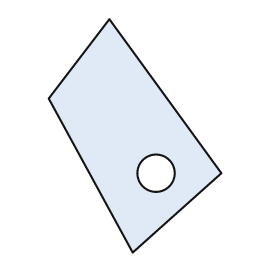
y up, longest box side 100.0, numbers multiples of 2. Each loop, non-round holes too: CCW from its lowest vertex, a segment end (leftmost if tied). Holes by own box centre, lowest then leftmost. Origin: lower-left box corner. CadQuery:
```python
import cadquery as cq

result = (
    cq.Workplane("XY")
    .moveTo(36.0, 0.0)
    .lineTo(74.0, 34.0)
    .lineTo(26.0, 100.0)
    .lineTo(0.0, 66.0)
    .close()
    .moveTo(46.0, 34.0)
    .circle(8.0)
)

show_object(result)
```